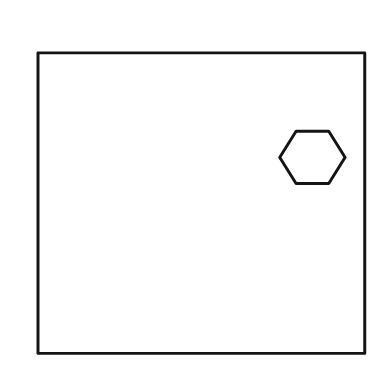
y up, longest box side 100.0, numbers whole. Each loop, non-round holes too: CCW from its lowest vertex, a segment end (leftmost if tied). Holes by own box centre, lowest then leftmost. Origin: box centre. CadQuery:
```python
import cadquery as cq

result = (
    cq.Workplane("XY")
    .moveTo(-50.0, -46.0)
    .lineTo(50.0, -46.0)
    .lineTo(50.0, 46.0)
    .lineTo(-50.0, 46.0)
    .close()
    .moveTo(29.0, 6.0)
    .lineTo(39.0, 6.0)
    .lineTo(44.0, 14.0)
    .lineTo(39.0, 22.0)
    .lineTo(29.0, 22.0)
    .lineTo(24.0, 14.0)
    .close()
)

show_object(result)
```